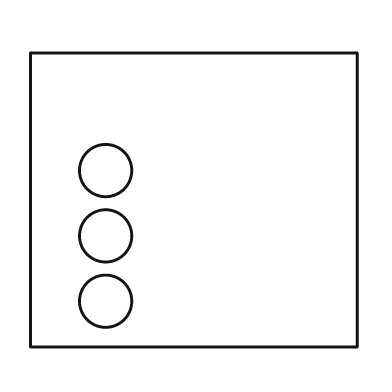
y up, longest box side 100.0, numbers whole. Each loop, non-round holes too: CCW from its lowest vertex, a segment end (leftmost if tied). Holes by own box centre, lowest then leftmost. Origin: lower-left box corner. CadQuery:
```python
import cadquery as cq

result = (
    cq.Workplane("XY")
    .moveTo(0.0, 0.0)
    .lineTo(100.0, 0.0)
    .lineTo(100.0, 90.0)
    .lineTo(0.0, 90.0)
    .close()
    .moveTo(23.0, 14.0)
    .circle(8.0)
    .moveTo(23.0, 34.0)
    .circle(8.0)
    .moveTo(23.0, 54.0)
    .circle(8.0)
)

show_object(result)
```